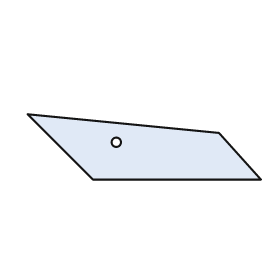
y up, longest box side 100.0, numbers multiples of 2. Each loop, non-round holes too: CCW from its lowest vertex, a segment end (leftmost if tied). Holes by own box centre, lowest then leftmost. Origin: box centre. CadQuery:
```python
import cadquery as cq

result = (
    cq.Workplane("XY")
    .moveTo(-22.0, -14.0)
    .lineTo(50.0, -14.0)
    .lineTo(32.0, 6.0)
    .lineTo(-50.0, 14.0)
    .close()
    .moveTo(-12.0, 2.0)
    .circle(2.0)
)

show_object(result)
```